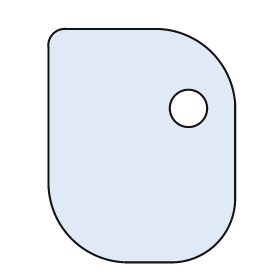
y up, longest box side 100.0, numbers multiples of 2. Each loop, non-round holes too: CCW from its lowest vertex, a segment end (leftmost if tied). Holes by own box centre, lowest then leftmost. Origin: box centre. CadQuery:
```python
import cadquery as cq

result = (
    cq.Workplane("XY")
    .moveTo(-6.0, -50.0)
    .lineTo(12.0, -50.0)
    .threePointArc((32.0, -42.0), (40.0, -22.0))
    .lineTo(40.0, 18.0)
    .threePointArc((30.0, 40.0), (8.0, 50.0))
    .lineTo(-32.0, 50.0)
    .threePointArc((-38.0, 48.0), (-40.0, 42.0))
    .lineTo(-40.0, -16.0)
    .threePointArc((-30.0, -40.0), (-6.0, -50.0))
    .close()
    .moveTo(20.0, 16.0)
    .circle(8.0)
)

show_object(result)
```